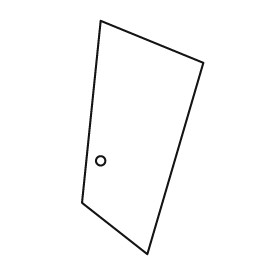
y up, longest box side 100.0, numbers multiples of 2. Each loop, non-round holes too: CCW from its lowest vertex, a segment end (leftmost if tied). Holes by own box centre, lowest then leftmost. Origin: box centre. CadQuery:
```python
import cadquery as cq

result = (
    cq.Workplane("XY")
    .moveTo(2.0, -50.0)
    .lineTo(26.0, 32.0)
    .lineTo(-18.0, 50.0)
    .lineTo(-26.0, -28.0)
    .close()
    .moveTo(-18.0, -10.0)
    .circle(2.0)
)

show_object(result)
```